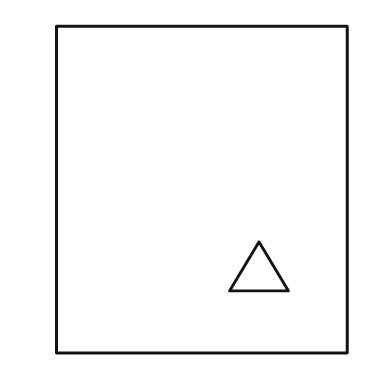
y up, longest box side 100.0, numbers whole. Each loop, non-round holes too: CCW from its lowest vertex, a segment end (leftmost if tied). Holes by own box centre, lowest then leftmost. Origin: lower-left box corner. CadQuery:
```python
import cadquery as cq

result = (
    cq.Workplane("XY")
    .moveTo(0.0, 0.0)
    .lineTo(89.0, 0.0)
    .lineTo(89.0, 100.0)
    .lineTo(0.0, 100.0)
    .close()
    .moveTo(53.0, 19.0)
    .lineTo(71.0, 19.0)
    .lineTo(62.0, 34.0)
    .close()
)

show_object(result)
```